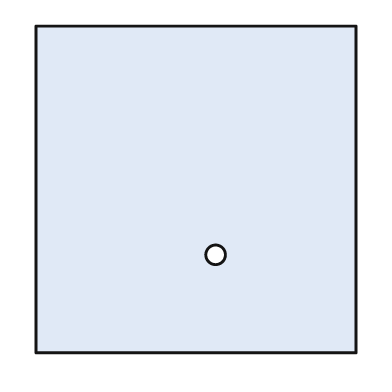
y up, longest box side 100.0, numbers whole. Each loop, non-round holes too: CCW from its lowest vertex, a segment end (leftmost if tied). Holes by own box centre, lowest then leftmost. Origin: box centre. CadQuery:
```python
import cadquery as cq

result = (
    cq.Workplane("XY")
    .moveTo(-49.0, -50.0)
    .lineTo(49.0, -50.0)
    .lineTo(49.0, 50.0)
    .lineTo(-49.0, 50.0)
    .close()
    .moveTo(6.0, -20.0)
    .circle(3.0)
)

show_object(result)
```